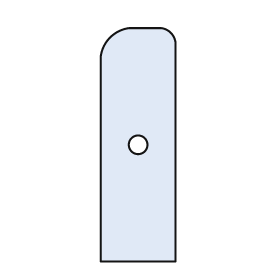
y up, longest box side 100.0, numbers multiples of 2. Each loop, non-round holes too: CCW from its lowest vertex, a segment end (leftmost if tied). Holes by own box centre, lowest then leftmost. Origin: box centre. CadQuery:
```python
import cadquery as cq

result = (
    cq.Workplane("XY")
    .moveTo(-16.0, -50.0)
    .lineTo(16.0, -50.0)
    .lineTo(16.0, 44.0)
    .threePointArc((14.0, 48.0), (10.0, 50.0))
    .lineTo(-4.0, 50.0)
    .threePointArc((-12.0, 46.0), (-16.0, 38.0))
    .close()
    .moveTo(0.0, 0.0)
    .circle(4.0)
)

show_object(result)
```